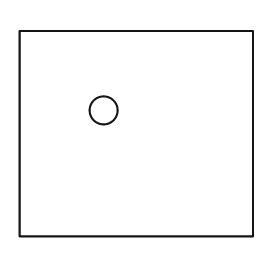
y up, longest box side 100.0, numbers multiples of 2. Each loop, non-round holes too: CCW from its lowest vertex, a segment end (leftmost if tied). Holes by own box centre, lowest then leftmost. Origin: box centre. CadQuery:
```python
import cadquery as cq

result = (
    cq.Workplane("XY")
    .moveTo(-50.0, -44.0)
    .lineTo(50.0, -44.0)
    .lineTo(50.0, 44.0)
    .lineTo(-50.0, 44.0)
    .close()
    .moveTo(-14.0, 10.0)
    .circle(6.0)
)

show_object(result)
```